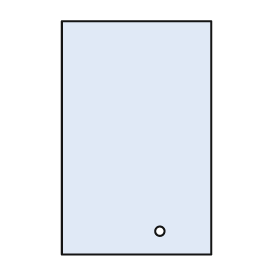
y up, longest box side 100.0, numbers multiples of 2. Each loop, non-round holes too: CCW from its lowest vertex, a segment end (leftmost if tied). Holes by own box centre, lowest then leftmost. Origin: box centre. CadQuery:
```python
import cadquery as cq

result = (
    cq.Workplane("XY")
    .moveTo(-32.0, -50.0)
    .lineTo(32.0, -50.0)
    .lineTo(32.0, 50.0)
    .lineTo(-32.0, 50.0)
    .close()
    .moveTo(10.0, -40.0)
    .circle(2.0)
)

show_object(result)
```